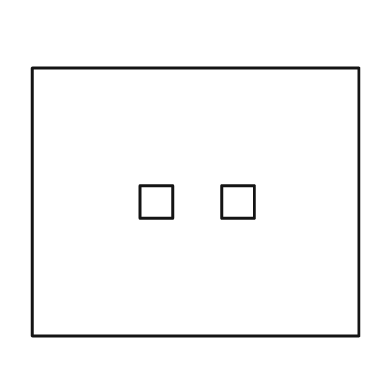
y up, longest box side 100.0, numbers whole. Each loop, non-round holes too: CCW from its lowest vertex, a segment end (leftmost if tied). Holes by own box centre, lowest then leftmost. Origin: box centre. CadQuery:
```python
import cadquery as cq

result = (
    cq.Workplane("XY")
    .moveTo(-50.0, -41.0)
    .lineTo(50.0, -41.0)
    .lineTo(50.0, 41.0)
    .lineTo(-50.0, 41.0)
    .close()
    .moveTo(-17.0, -5.0)
    .lineTo(-7.0, -5.0)
    .lineTo(-7.0, 5.0)
    .lineTo(-17.0, 5.0)
    .close()
    .moveTo(8.0, -5.0)
    .lineTo(18.0, -5.0)
    .lineTo(18.0, 5.0)
    .lineTo(8.0, 5.0)
    .close()
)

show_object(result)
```